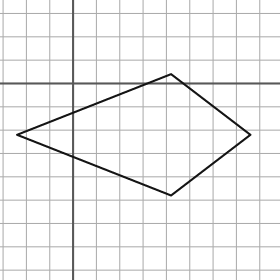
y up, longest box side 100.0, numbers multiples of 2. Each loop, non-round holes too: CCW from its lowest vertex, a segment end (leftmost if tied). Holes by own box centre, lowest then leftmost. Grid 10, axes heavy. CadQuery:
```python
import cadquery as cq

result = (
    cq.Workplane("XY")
    .moveTo(42.0, -48.0)
    .lineTo(76.0, -22.0)
    .lineTo(42.0, 4.0)
    .lineTo(-24.0, -22.0)
    .close()
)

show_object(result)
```